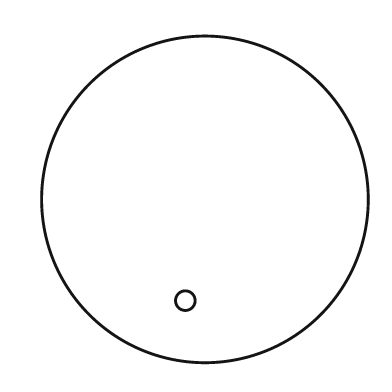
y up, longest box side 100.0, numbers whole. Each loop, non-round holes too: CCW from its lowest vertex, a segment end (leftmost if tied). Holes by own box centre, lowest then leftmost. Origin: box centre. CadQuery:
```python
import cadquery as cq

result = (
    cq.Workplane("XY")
    .moveTo(0.0, 0.0)
    .circle(50.0)
    .moveTo(-6.0, -31.0)
    .circle(3.0)
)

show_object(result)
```